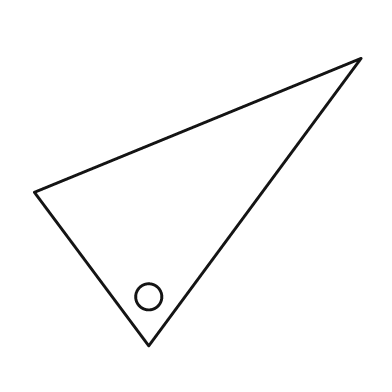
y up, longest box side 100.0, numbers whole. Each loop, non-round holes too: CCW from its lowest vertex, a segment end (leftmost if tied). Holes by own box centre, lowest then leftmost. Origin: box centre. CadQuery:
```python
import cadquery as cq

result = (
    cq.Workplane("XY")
    .moveTo(-15.0, -44.0)
    .lineTo(50.0, 44.0)
    .lineTo(-50.0, 3.0)
    .close()
    .moveTo(-15.0, -29.0)
    .circle(4.0)
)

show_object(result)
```